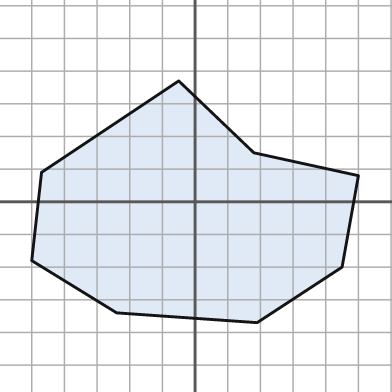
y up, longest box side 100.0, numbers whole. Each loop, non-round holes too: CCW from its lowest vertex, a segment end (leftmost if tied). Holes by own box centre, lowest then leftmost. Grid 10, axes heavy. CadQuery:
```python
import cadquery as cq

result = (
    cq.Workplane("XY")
    .moveTo(19.0, -37.0)
    .lineTo(45.0, -20.0)
    .lineTo(50.0, 8.0)
    .lineTo(18.0, 15.0)
    .lineTo(-5.0, 37.0)
    .lineTo(-47.0, 9.0)
    .lineTo(-50.0, -18.0)
    .lineTo(-24.0, -34.0)
    .close()
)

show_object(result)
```